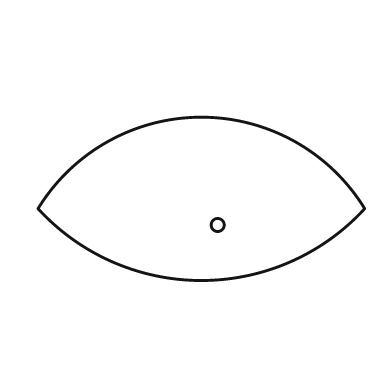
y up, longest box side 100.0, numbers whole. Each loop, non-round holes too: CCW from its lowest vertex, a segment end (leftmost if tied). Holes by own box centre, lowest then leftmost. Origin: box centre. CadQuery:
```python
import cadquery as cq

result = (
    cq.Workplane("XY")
    .moveTo(-50.0, -3.0)
    .threePointArc((0.0, -25.0), (50.0, -3.0))
    .threePointArc((0.0, 25.0), (-50.0, -3.0))
    .close()
    .moveTo(5.0, -8.0)
    .circle(2.0)
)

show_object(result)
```